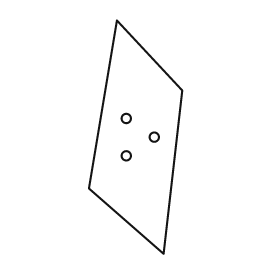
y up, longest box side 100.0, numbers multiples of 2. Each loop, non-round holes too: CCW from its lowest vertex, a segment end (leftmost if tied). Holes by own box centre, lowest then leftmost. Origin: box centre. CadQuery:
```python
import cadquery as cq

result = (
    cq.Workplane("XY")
    .moveTo(12.0, -50.0)
    .lineTo(20.0, 20.0)
    .lineTo(-8.0, 50.0)
    .lineTo(-20.0, -22.0)
    .close()
    .moveTo(-4.0, -8.0)
    .circle(2.0)
    .moveTo(8.0, 0.0)
    .circle(2.0)
    .moveTo(-4.0, 8.0)
    .circle(2.0)
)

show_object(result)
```